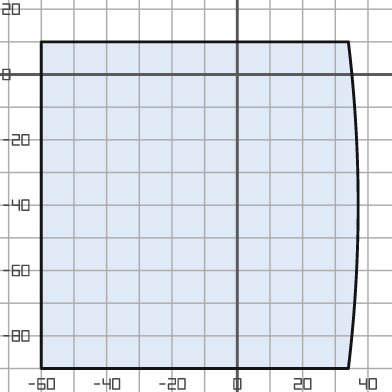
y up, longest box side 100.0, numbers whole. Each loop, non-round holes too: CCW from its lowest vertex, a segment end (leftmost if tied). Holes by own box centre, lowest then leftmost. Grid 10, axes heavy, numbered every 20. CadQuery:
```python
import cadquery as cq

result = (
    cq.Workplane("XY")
    .moveTo(-60.0, -90.0)
    .lineTo(34.0, -90.0)
    .threePointArc((37.0, -40.0), (34.0, 10.0))
    .lineTo(-60.0, 10.0)
    .close()
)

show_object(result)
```